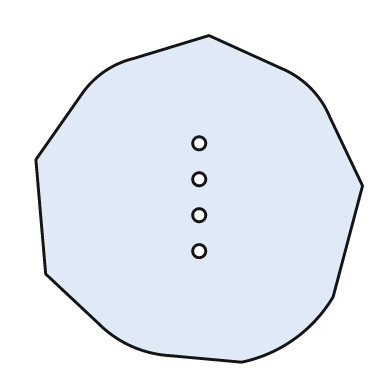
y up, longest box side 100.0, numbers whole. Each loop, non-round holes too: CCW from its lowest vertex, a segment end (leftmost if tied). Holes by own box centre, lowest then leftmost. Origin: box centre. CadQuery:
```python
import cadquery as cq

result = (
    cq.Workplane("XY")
    .moveTo(13.0, -50.0)
    .threePointArc((29.0, -43.0), (41.0, -30.0))
    .lineTo(50.0, 4.0)
    .lineTo(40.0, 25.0)
    .threePointArc((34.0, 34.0), (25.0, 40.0))
    .lineTo(3.0, 50.0)
    .lineTo(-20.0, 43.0)
    .threePointArc((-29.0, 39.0), (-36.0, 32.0))
    .lineTo(-50.0, 12.0)
    .lineTo(-47.0, -23.0)
    .lineTo(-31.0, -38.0)
    .threePointArc((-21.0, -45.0), (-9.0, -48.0))
    .close()
    .moveTo(0.0, -16.0)
    .circle(2.0)
    .moveTo(0.0, -5.0)
    .circle(2.0)
    .moveTo(0.0, 6.0)
    .circle(2.0)
    .moveTo(0.0, 17.0)
    .circle(2.0)
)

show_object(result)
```